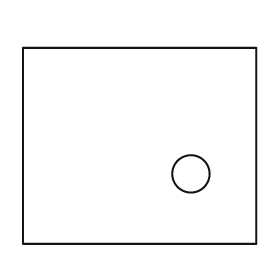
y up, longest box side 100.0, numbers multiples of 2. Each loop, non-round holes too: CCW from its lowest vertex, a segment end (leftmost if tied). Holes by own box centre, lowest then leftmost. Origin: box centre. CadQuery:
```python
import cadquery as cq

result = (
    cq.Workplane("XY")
    .moveTo(-50.0, -42.0)
    .lineTo(50.0, -42.0)
    .lineTo(50.0, 42.0)
    .lineTo(-50.0, 42.0)
    .close()
    .moveTo(22.0, -12.0)
    .circle(8.0)
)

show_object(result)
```